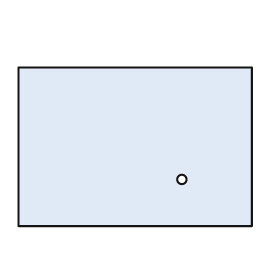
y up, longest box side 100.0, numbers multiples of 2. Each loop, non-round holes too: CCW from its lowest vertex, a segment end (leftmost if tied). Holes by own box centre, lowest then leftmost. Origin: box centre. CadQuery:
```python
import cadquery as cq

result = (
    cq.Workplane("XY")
    .moveTo(-50.0, -34.0)
    .lineTo(50.0, -34.0)
    .lineTo(50.0, 34.0)
    .lineTo(-50.0, 34.0)
    .close()
    .moveTo(20.0, -14.0)
    .circle(2.0)
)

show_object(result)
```